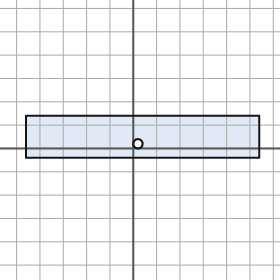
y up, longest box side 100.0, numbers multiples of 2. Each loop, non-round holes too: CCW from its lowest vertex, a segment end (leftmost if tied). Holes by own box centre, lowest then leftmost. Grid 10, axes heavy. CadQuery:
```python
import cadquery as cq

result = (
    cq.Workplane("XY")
    .moveTo(-46.0, -4.0)
    .lineTo(54.0, -4.0)
    .lineTo(54.0, 14.0)
    .lineTo(-46.0, 14.0)
    .close()
    .moveTo(2.0, 2.0)
    .circle(2.0)
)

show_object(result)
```